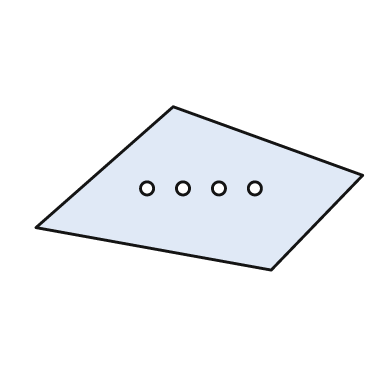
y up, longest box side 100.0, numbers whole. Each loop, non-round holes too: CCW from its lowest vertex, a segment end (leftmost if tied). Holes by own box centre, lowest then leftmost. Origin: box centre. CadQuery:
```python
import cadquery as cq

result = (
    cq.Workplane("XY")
    .moveTo(22.0, -25.0)
    .lineTo(50.0, 4.0)
    .lineTo(-8.0, 25.0)
    .lineTo(-50.0, -12.0)
    .close()
    .moveTo(-16.0, 0.0)
    .circle(2.0)
    .moveTo(-5.0, 0.0)
    .circle(2.0)
    .moveTo(6.0, 0.0)
    .circle(2.0)
    .moveTo(17.0, 0.0)
    .circle(2.0)
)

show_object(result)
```